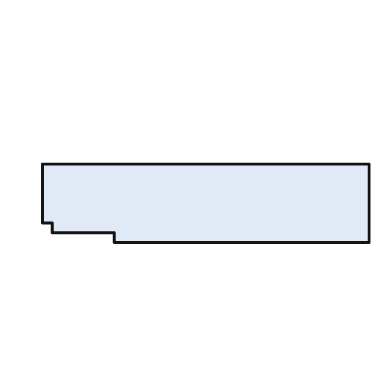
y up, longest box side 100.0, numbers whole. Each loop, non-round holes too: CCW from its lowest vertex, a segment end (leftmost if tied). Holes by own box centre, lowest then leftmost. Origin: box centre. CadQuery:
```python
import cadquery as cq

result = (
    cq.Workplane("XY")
    .moveTo(-28.0, -12.0)
    .lineTo(50.0, -12.0)
    .lineTo(50.0, 12.0)
    .lineTo(-50.0, 12.0)
    .lineTo(-50.0, -6.0)
    .lineTo(-47.0, -6.0)
    .lineTo(-47.0, -9.0)
    .lineTo(-28.0, -9.0)
    .close()
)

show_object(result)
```